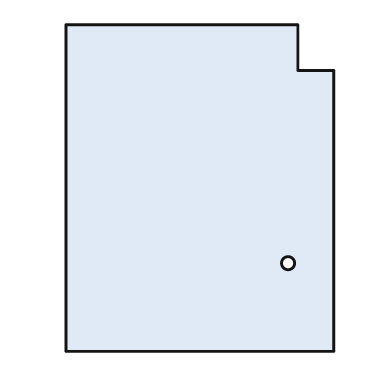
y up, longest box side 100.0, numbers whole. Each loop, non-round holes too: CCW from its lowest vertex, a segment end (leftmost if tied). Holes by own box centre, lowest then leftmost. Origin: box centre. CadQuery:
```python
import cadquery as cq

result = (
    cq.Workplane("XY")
    .moveTo(-41.0, -50.0)
    .lineTo(41.0, -50.0)
    .lineTo(41.0, 36.0)
    .lineTo(30.0, 36.0)
    .lineTo(30.0, 50.0)
    .lineTo(-41.0, 50.0)
    .close()
    .moveTo(27.0, -23.0)
    .circle(2.0)
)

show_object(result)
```